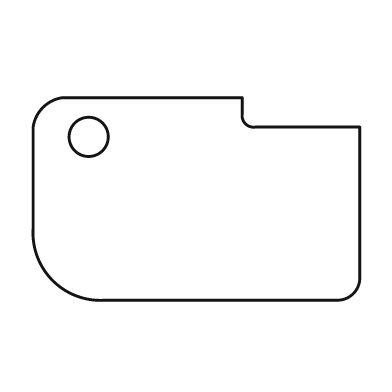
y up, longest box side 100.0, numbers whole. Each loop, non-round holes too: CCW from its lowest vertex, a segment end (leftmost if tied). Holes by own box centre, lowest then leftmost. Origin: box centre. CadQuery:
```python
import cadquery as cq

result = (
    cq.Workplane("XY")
    .moveTo(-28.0, -31.0)
    .lineTo(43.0, -31.0)
    .threePointArc((48.0, -29.0), (50.0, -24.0))
    .lineTo(50.0, 22.0)
    .lineTo(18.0, 22.0)
    .threePointArc((15.0, 23.0), (14.0, 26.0))
    .lineTo(14.0, 31.0)
    .lineTo(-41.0, 31.0)
    .threePointArc((-47.0, 28.0), (-50.0, 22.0))
    .lineTo(-50.0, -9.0)
    .threePointArc((-44.0, -25.0), (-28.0, -31.0))
    .close()
    .moveTo(-33.0, 19.0)
    .circle(6.0)
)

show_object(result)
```